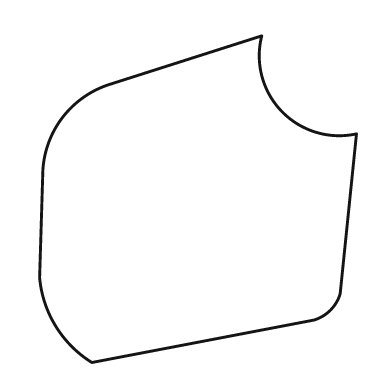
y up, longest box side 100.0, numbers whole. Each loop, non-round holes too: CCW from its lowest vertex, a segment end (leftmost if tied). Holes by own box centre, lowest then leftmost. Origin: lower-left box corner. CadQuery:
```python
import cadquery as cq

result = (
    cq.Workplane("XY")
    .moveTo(16.0, 0.0)
    .lineTo(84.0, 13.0)
    .threePointArc((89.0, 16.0), (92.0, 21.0))
    .lineTo(97.0, 70.0)
    .threePointArc((74.0, 77.0), (68.0, 100.0))
    .lineTo(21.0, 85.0)
    .threePointArc((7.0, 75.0), (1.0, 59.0))
    .lineTo(0.0, 26.0)
    .threePointArc((5.0, 11.0), (16.0, 0.0))
    .close()
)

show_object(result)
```